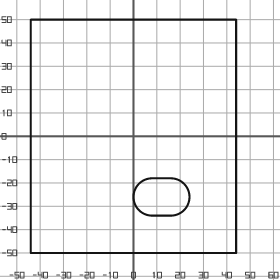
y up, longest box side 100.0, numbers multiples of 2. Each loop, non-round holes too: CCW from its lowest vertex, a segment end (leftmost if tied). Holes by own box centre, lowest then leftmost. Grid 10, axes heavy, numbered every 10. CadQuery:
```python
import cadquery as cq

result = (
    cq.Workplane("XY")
    .moveTo(-44.0, -50.0)
    .lineTo(44.0, -50.0)
    .lineTo(44.0, 50.0)
    .lineTo(-44.0, 50.0)
    .close()
    .moveTo(8.0, -34.0)
    .lineTo(16.0, -34.0)
    .threePointArc((24.0, -26.0), (16.0, -18.0))
    .lineTo(8.0, -18.0)
    .threePointArc((0.0, -26.0), (8.0, -34.0))
    .close()
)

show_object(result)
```